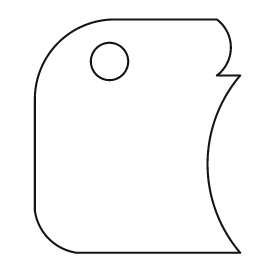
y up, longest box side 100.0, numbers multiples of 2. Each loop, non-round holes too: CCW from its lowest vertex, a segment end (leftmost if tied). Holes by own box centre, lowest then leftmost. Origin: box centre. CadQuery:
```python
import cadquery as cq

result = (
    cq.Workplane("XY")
    .moveTo(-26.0, -50.0)
    .lineTo(44.0, -50.0)
    .threePointArc((30.0, -12.0), (44.0, 26.0))
    .lineTo(34.0, 26.0)
    .threePointArc((40.0, 38.0), (34.0, 50.0))
    .lineTo(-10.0, 50.0)
    .threePointArc((-34.0, 40.0), (-44.0, 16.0))
    .lineTo(-44.0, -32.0)
    .threePointArc((-38.0, -44.0), (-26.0, -50.0))
    .close()
    .moveTo(-12.0, 32.0)
    .circle(8.0)
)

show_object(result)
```